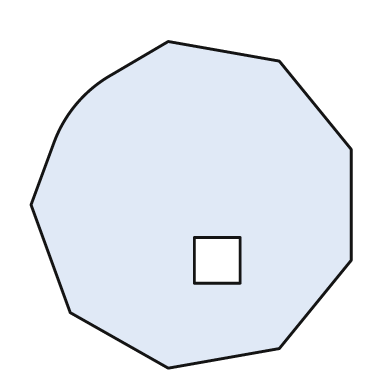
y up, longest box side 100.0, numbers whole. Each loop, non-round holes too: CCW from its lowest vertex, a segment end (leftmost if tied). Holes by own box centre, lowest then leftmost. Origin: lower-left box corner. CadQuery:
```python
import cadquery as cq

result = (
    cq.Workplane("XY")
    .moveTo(42.0, 0.0)
    .lineTo(76.0, 6.0)
    .lineTo(98.0, 33.0)
    .lineTo(98.0, 67.0)
    .lineTo(76.0, 94.0)
    .lineTo(42.0, 100.0)
    .lineTo(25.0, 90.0)
    .threePointArc((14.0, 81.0), (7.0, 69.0))
    .lineTo(0.0, 50.0)
    .lineTo(12.0, 17.0)
    .close()
    .moveTo(50.0, 26.0)
    .lineTo(64.0, 26.0)
    .lineTo(64.0, 40.0)
    .lineTo(50.0, 40.0)
    .close()
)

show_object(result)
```